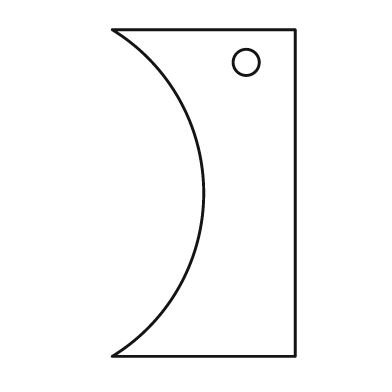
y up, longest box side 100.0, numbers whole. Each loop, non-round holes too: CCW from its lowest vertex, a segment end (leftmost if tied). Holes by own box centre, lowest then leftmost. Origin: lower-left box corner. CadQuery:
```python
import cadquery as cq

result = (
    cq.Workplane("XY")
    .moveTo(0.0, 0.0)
    .lineTo(56.0, 0.0)
    .lineTo(56.0, 100.0)
    .lineTo(0.0, 100.0)
    .threePointArc((28.0, 50.0), (0.0, 0.0))
    .close()
    .moveTo(41.0, 90.0)
    .circle(4.0)
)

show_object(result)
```